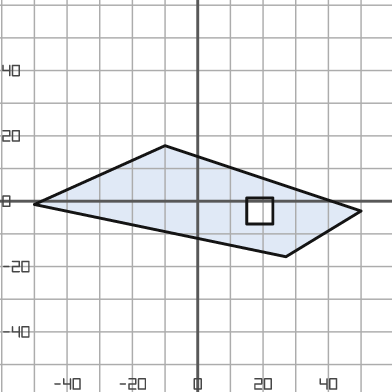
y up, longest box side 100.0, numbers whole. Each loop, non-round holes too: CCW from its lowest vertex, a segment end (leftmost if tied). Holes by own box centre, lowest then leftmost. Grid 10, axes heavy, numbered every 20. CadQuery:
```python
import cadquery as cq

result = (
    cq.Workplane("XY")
    .moveTo(27.0, -17.0)
    .lineTo(50.0, -3.0)
    .lineTo(-10.0, 17.0)
    .lineTo(-50.0, -1.0)
    .close()
    .moveTo(15.0, -7.0)
    .lineTo(23.0, -7.0)
    .lineTo(23.0, 1.0)
    .lineTo(15.0, 1.0)
    .close()
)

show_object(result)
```